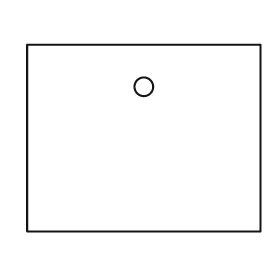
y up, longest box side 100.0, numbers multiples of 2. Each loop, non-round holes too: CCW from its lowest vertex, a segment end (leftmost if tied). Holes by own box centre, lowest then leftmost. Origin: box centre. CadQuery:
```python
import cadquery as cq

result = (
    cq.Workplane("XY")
    .moveTo(-50.0, -40.0)
    .lineTo(50.0, -40.0)
    .lineTo(50.0, 40.0)
    .lineTo(-50.0, 40.0)
    .close()
    .moveTo(0.0, 22.0)
    .circle(4.0)
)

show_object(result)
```